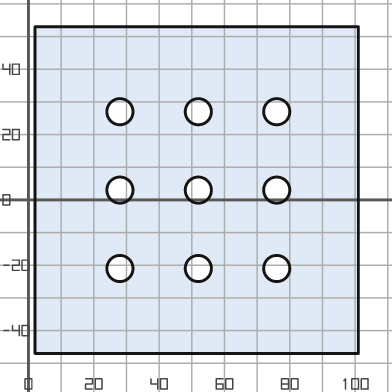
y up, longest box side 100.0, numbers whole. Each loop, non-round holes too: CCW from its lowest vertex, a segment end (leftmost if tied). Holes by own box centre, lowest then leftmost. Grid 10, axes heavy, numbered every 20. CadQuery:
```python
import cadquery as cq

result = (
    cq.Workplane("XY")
    .moveTo(2.0, -47.0)
    .lineTo(101.0, -47.0)
    .lineTo(101.0, 53.0)
    .lineTo(2.0, 53.0)
    .close()
    .moveTo(28.0, -21.0)
    .circle(4.0)
    .moveTo(52.0, -21.0)
    .circle(4.0)
    .moveTo(76.0, -21.0)
    .circle(4.0)
    .moveTo(28.0, 3.0)
    .circle(4.0)
    .moveTo(52.0, 3.0)
    .circle(4.0)
    .moveTo(76.0, 3.0)
    .circle(4.0)
    .moveTo(28.0, 27.0)
    .circle(4.0)
    .moveTo(52.0, 27.0)
    .circle(4.0)
    .moveTo(76.0, 27.0)
    .circle(4.0)
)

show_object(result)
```